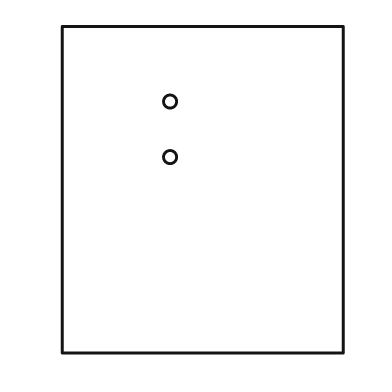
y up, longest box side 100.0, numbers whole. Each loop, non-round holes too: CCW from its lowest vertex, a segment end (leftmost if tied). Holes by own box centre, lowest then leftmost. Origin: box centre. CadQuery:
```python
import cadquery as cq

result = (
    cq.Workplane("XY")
    .moveTo(-43.0, -50.0)
    .lineTo(43.0, -50.0)
    .lineTo(43.0, 50.0)
    .lineTo(-43.0, 50.0)
    .close()
    .moveTo(-10.0, 10.0)
    .circle(2.0)
    .moveTo(-10.0, 27.0)
    .circle(2.0)
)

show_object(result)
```